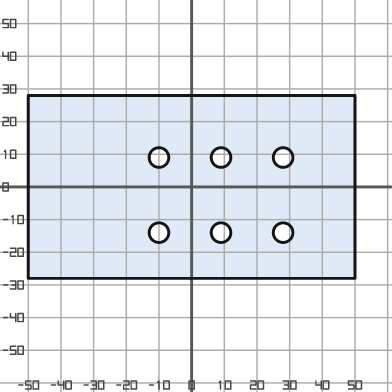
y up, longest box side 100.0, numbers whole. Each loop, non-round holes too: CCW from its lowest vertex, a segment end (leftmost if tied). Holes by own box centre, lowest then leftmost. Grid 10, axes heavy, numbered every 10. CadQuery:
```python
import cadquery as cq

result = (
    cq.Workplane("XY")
    .moveTo(-50.0, -28.0)
    .lineTo(50.0, -28.0)
    .lineTo(50.0, 28.0)
    .lineTo(-50.0, 28.0)
    .close()
    .moveTo(-10.0, -14.0)
    .circle(3.0)
    .moveTo(9.0, -14.0)
    .circle(3.0)
    .moveTo(28.0, -14.0)
    .circle(3.0)
    .moveTo(-10.0, 9.0)
    .circle(3.0)
    .moveTo(9.0, 9.0)
    .circle(3.0)
    .moveTo(28.0, 9.0)
    .circle(3.0)
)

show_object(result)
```